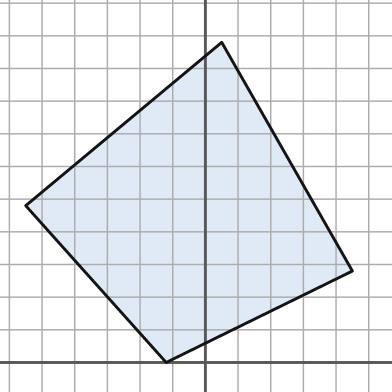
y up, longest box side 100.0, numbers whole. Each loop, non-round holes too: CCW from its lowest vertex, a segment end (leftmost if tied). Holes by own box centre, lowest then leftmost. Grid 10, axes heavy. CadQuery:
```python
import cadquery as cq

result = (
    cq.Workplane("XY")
    .moveTo(-12.0, 0.0)
    .lineTo(45.0, 28.0)
    .lineTo(5.0, 98.0)
    .lineTo(-55.0, 48.0)
    .close()
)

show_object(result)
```